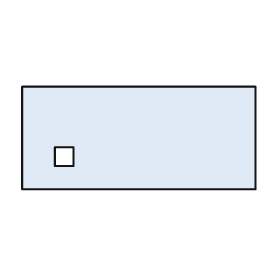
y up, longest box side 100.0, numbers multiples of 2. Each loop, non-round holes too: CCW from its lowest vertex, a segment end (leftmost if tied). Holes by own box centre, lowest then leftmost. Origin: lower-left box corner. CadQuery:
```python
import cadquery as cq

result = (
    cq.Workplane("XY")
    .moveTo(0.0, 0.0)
    .lineTo(100.0, 0.0)
    .lineTo(100.0, 44.0)
    .lineTo(0.0, 44.0)
    .close()
    .moveTo(14.0, 10.0)
    .lineTo(22.0, 10.0)
    .lineTo(22.0, 18.0)
    .lineTo(14.0, 18.0)
    .close()
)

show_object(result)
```